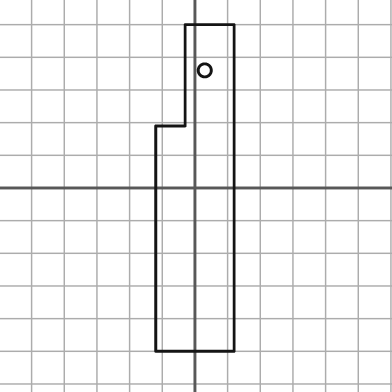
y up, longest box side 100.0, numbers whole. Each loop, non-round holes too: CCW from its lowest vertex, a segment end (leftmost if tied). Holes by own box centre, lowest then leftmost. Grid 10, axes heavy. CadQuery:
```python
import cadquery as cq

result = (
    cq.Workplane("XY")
    .moveTo(-12.0, -50.0)
    .lineTo(12.0, -50.0)
    .lineTo(12.0, 50.0)
    .lineTo(-3.0, 50.0)
    .lineTo(-3.0, 19.0)
    .lineTo(-12.0, 19.0)
    .close()
    .moveTo(3.0, 36.0)
    .circle(2.0)
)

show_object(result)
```